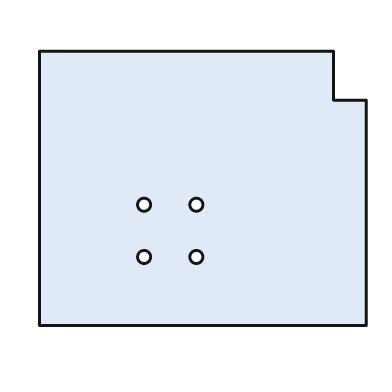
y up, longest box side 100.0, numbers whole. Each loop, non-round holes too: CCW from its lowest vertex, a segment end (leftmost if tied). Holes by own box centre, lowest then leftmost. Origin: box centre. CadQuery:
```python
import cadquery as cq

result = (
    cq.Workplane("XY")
    .moveTo(-50.0, -42.0)
    .lineTo(50.0, -42.0)
    .lineTo(50.0, 27.0)
    .lineTo(40.0, 27.0)
    .lineTo(40.0, 42.0)
    .lineTo(-50.0, 42.0)
    .close()
    .moveTo(-18.0, -21.0)
    .circle(2.0)
    .moveTo(-2.0, -21.0)
    .circle(2.0)
    .moveTo(-18.0, -5.0)
    .circle(2.0)
    .moveTo(-2.0, -5.0)
    .circle(2.0)
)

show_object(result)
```